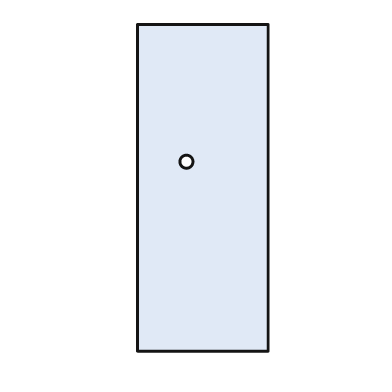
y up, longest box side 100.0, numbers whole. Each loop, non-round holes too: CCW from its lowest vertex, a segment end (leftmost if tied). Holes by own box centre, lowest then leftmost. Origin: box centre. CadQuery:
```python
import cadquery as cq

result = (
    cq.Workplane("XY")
    .moveTo(-20.0, -50.0)
    .lineTo(20.0, -50.0)
    .lineTo(20.0, 50.0)
    .lineTo(-20.0, 50.0)
    .close()
    .moveTo(-5.0, 8.0)
    .circle(2.0)
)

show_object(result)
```